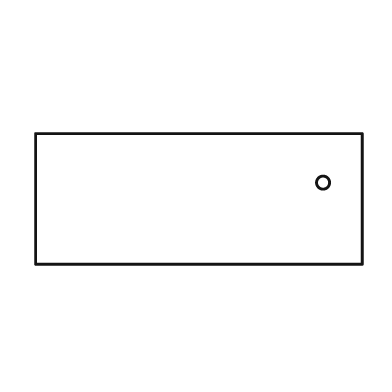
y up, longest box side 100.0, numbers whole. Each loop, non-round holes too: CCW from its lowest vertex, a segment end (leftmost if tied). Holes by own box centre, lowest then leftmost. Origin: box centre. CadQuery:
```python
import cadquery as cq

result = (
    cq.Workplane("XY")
    .moveTo(-50.0, -20.0)
    .lineTo(50.0, -20.0)
    .lineTo(50.0, 20.0)
    .lineTo(-50.0, 20.0)
    .close()
    .moveTo(38.0, 5.0)
    .circle(2.0)
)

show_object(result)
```